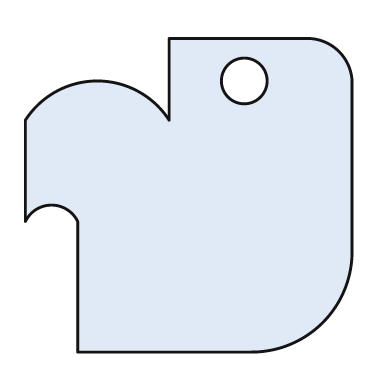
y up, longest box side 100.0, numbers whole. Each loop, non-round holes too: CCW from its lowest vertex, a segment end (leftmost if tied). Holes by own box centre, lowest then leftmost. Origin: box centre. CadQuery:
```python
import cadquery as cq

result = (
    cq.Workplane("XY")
    .moveTo(-34.0, -48.0)
    .lineTo(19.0, -48.0)
    .threePointArc((41.0, -39.0), (50.0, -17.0))
    .lineTo(50.0, 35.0)
    .threePointArc((46.0, 44.0), (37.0, 48.0))
    .lineTo(-6.0, 48.0)
    .lineTo(-6.0, 23.0)
    .threePointArc((-28.0, 35.0), (-50.0, 23.0))
    .lineTo(-50.0, -8.0)
    .threePointArc((-42.0, -3.0), (-34.0, -8.0))
    .close()
    .moveTo(17.0, 35.0)
    .circle(7.0)
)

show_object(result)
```